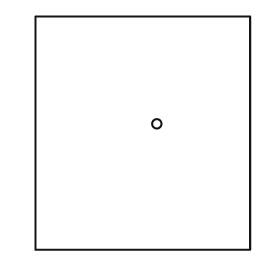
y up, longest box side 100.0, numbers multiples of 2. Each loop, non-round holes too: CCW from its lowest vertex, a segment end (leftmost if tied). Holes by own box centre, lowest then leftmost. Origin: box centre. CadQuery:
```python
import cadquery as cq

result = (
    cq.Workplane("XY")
    .moveTo(-46.0, -50.0)
    .lineTo(46.0, -50.0)
    .lineTo(46.0, 50.0)
    .lineTo(-46.0, 50.0)
    .close()
    .moveTo(6.0, 4.0)
    .circle(2.0)
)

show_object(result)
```